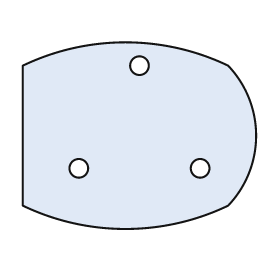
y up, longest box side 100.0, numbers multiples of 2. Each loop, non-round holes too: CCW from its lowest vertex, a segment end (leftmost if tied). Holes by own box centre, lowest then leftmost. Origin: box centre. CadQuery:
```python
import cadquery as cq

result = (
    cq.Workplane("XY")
    .moveTo(-50.0, -30.0)
    .threePointArc((-6.0, -40.0), (38.0, -30.0))
    .threePointArc((50.0, 0.0), (38.0, 30.0))
    .threePointArc((-6.0, 40.0), (-50.0, 30.0))
    .close()
    .moveTo(-26.0, -14.0)
    .circle(4.0)
    .moveTo(26.0, -14.0)
    .circle(4.0)
    .moveTo(0.0, 30.0)
    .circle(4.0)
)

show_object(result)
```